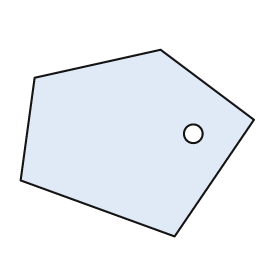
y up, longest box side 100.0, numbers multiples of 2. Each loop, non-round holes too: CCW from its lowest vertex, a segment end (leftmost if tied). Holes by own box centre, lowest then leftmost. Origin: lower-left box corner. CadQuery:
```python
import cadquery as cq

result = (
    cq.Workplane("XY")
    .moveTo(66.0, 0.0)
    .lineTo(100.0, 50.0)
    .lineTo(60.0, 80.0)
    .lineTo(6.0, 68.0)
    .lineTo(0.0, 24.0)
    .close()
    .moveTo(74.0, 44.0)
    .circle(4.0)
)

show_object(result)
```